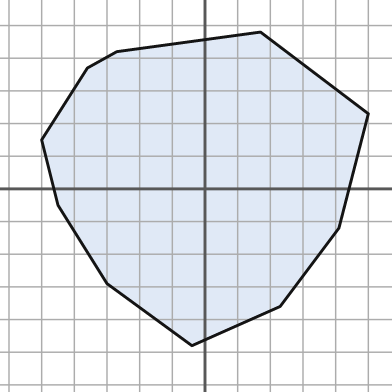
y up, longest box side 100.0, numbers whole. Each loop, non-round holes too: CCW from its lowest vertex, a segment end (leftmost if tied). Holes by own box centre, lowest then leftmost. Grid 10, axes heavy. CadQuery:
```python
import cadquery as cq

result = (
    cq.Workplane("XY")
    .moveTo(-4.0, -48.0)
    .lineTo(23.0, -36.0)
    .lineTo(41.0, -12.0)
    .lineTo(50.0, 23.0)
    .lineTo(17.0, 48.0)
    .lineTo(-27.0, 42.0)
    .lineTo(-36.0, 37.0)
    .lineTo(-50.0, 15.0)
    .lineTo(-45.0, -5.0)
    .lineTo(-30.0, -29.0)
    .close()
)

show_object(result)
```